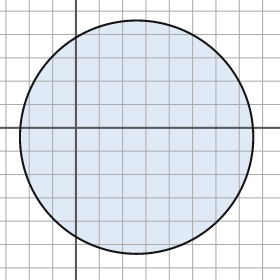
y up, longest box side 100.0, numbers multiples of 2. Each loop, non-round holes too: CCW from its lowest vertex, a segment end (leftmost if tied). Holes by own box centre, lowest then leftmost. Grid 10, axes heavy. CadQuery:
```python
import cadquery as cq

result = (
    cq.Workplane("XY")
    .moveTo(26.0, -4.0)
    .circle(50.0)
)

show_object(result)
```